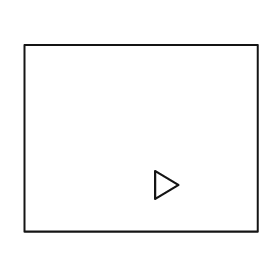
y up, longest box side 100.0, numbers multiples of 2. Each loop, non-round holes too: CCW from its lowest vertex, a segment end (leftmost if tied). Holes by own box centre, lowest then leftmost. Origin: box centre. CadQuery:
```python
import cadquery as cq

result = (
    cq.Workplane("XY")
    .moveTo(-50.0, -40.0)
    .lineTo(50.0, -40.0)
    .lineTo(50.0, 40.0)
    .lineTo(-50.0, 40.0)
    .close()
    .moveTo(6.0, -26.0)
    .lineTo(16.0, -20.0)
    .lineTo(6.0, -14.0)
    .close()
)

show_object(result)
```